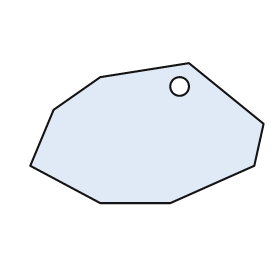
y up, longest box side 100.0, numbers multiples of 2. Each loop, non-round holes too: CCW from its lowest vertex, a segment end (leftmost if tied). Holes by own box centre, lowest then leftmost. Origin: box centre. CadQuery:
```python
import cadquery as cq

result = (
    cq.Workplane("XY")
    .moveTo(-20.0, -30.0)
    .lineTo(10.0, -30.0)
    .lineTo(46.0, -14.0)
    .lineTo(50.0, 4.0)
    .lineTo(18.0, 30.0)
    .lineTo(-20.0, 24.0)
    .lineTo(-40.0, 10.0)
    .lineTo(-50.0, -14.0)
    .close()
    .moveTo(14.0, 20.0)
    .circle(4.0)
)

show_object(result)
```